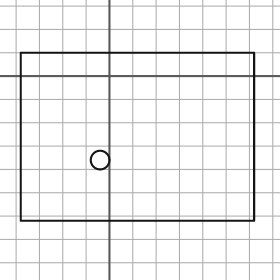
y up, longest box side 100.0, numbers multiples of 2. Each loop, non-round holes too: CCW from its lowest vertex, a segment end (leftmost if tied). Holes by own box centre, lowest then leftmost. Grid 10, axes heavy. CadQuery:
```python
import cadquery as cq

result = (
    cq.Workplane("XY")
    .moveTo(-38.0, -62.0)
    .lineTo(62.0, -62.0)
    .lineTo(62.0, 10.0)
    .lineTo(-38.0, 10.0)
    .close()
    .moveTo(-4.0, -36.0)
    .circle(4.0)
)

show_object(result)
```